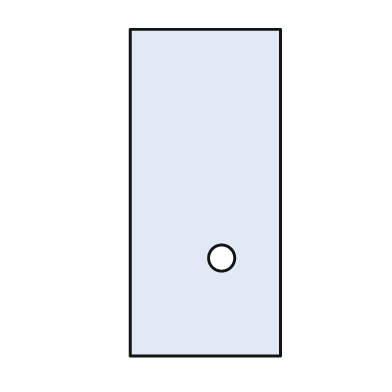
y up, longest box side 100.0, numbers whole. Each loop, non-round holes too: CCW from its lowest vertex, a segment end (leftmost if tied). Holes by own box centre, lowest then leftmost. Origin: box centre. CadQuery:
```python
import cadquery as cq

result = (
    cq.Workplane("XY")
    .moveTo(-23.0, -50.0)
    .lineTo(23.0, -50.0)
    .lineTo(23.0, 50.0)
    .lineTo(-23.0, 50.0)
    .close()
    .moveTo(5.0, -20.0)
    .circle(4.0)
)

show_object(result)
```